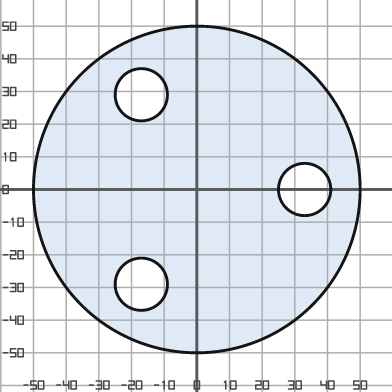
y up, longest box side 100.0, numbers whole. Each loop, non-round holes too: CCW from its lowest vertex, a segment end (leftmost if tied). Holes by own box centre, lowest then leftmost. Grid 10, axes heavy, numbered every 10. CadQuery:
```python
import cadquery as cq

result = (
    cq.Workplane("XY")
    .moveTo(0.0, 0.0)
    .circle(50.0)
    .moveTo(-17.0, -29.0)
    .circle(8.0)
    .moveTo(33.0, 0.0)
    .circle(8.0)
    .moveTo(-17.0, 29.0)
    .circle(8.0)
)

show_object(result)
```